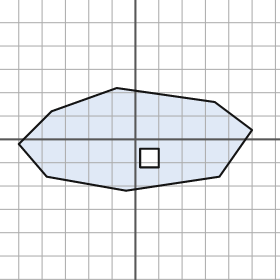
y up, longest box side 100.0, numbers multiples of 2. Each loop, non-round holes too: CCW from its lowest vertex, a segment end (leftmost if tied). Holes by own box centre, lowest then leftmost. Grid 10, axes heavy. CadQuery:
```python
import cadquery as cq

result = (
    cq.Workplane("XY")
    .moveTo(-4.0, -22.0)
    .lineTo(36.0, -16.0)
    .lineTo(50.0, 4.0)
    .lineTo(34.0, 16.0)
    .lineTo(-8.0, 22.0)
    .lineTo(-36.0, 12.0)
    .lineTo(-50.0, -2.0)
    .lineTo(-38.0, -16.0)
    .close()
    .moveTo(2.0, -12.0)
    .lineTo(10.0, -12.0)
    .lineTo(10.0, -4.0)
    .lineTo(2.0, -4.0)
    .close()
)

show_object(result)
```